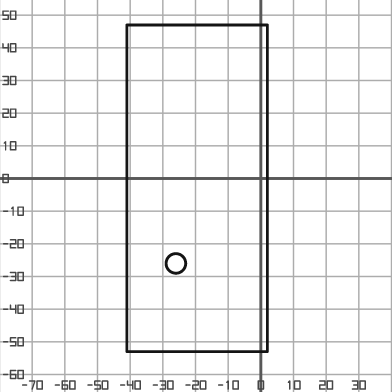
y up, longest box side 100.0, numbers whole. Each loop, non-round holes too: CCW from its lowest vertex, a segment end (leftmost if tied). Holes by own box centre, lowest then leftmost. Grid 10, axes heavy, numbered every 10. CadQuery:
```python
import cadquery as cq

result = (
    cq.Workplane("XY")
    .moveTo(-41.0, -53.0)
    .lineTo(2.0, -53.0)
    .lineTo(2.0, 47.0)
    .lineTo(-41.0, 47.0)
    .close()
    .moveTo(-26.0, -26.0)
    .circle(3.0)
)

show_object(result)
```